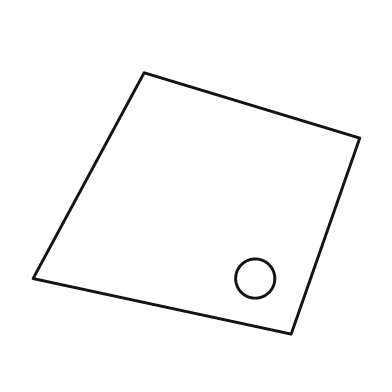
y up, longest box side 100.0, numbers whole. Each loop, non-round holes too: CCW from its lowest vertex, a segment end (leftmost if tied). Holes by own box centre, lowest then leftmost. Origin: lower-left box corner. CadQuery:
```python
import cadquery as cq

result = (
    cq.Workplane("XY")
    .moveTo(79.0, 0.0)
    .lineTo(100.0, 60.0)
    .lineTo(34.0, 80.0)
    .lineTo(0.0, 17.0)
    .close()
    .moveTo(68.0, 17.0)
    .circle(6.0)
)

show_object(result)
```